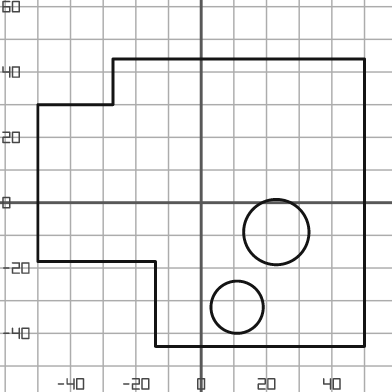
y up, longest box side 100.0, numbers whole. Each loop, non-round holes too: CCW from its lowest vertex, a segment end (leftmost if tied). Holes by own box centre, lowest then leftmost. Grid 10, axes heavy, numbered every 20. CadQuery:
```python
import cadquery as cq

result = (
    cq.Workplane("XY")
    .moveTo(-14.0, -44.0)
    .lineTo(50.0, -44.0)
    .lineTo(50.0, 44.0)
    .lineTo(-27.0, 44.0)
    .lineTo(-27.0, 30.0)
    .lineTo(-50.0, 30.0)
    .lineTo(-50.0, -18.0)
    .lineTo(-14.0, -18.0)
    .close()
    .moveTo(11.0, -32.0)
    .circle(8.0)
    .moveTo(23.0, -9.0)
    .circle(10.0)
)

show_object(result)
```